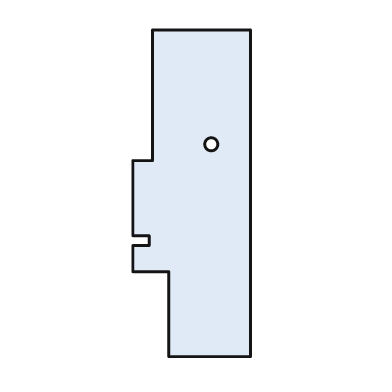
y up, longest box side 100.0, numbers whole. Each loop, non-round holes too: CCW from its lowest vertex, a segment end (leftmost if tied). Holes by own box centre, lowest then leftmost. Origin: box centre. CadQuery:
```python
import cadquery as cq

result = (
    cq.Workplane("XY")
    .moveTo(-7.0, -50.0)
    .lineTo(18.0, -50.0)
    .lineTo(18.0, 50.0)
    .lineTo(-12.0, 50.0)
    .lineTo(-12.0, 10.0)
    .lineTo(-18.0, 10.0)
    .lineTo(-18.0, -13.0)
    .lineTo(-13.0, -13.0)
    .lineTo(-13.0, -16.0)
    .lineTo(-18.0, -16.0)
    .lineTo(-18.0, -24.0)
    .lineTo(-7.0, -24.0)
    .close()
    .moveTo(6.0, 15.0)
    .circle(2.0)
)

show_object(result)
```